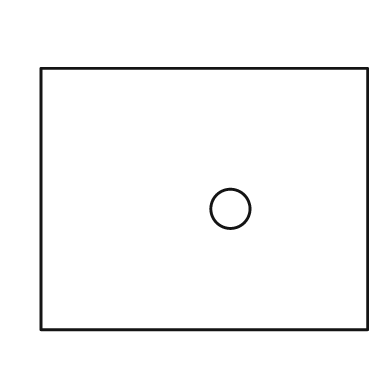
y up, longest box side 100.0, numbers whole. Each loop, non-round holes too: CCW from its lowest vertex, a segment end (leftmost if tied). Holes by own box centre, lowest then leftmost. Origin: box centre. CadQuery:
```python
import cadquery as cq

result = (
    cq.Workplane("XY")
    .moveTo(-50.0, -40.0)
    .lineTo(50.0, -40.0)
    .lineTo(50.0, 40.0)
    .lineTo(-50.0, 40.0)
    .close()
    .moveTo(8.0, -3.0)
    .circle(6.0)
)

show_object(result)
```